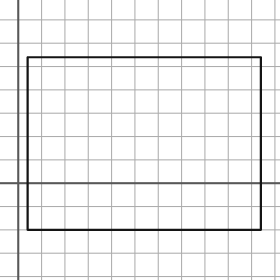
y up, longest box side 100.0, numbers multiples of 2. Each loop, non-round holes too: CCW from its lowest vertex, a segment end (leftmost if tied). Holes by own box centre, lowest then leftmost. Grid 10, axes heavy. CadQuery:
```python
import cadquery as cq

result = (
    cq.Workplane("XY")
    .moveTo(4.0, -20.0)
    .lineTo(104.0, -20.0)
    .lineTo(104.0, 54.0)
    .lineTo(4.0, 54.0)
    .close()
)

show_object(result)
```